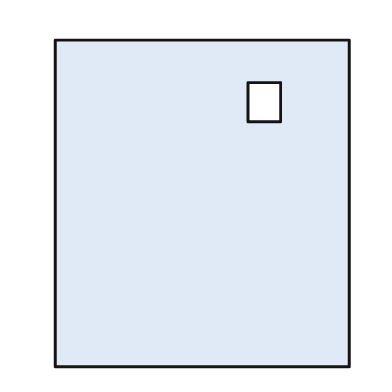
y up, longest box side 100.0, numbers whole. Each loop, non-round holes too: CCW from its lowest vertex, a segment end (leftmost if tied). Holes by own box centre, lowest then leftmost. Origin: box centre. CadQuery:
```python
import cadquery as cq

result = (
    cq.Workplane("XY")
    .moveTo(-45.0, -50.0)
    .lineTo(45.0, -50.0)
    .lineTo(45.0, 50.0)
    .lineTo(-45.0, 50.0)
    .close()
    .moveTo(14.0, 25.0)
    .lineTo(24.0, 25.0)
    .lineTo(24.0, 37.0)
    .lineTo(14.0, 37.0)
    .close()
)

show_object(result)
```